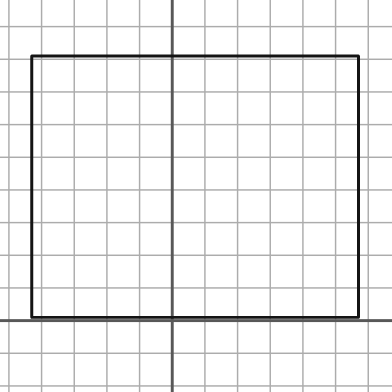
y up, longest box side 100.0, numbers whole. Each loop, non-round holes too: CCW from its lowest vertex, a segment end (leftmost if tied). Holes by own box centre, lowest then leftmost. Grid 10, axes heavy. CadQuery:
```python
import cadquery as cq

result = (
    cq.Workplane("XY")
    .moveTo(-43.0, 1.0)
    .lineTo(57.0, 1.0)
    .lineTo(57.0, 81.0)
    .lineTo(-43.0, 81.0)
    .close()
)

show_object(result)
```